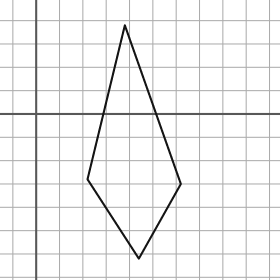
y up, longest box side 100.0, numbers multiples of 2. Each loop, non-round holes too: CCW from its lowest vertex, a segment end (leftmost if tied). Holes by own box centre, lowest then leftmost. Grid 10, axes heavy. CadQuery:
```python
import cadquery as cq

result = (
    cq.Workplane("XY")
    .moveTo(44.0, -62.0)
    .lineTo(62.0, -30.0)
    .lineTo(38.0, 38.0)
    .lineTo(22.0, -28.0)
    .close()
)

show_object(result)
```